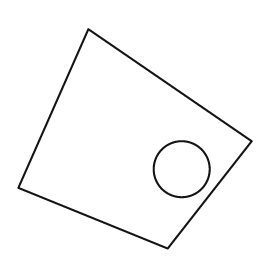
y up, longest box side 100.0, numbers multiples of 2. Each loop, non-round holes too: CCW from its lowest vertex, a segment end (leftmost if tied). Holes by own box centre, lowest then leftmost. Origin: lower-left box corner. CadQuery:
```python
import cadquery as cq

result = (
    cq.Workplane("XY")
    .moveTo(64.0, 0.0)
    .lineTo(100.0, 46.0)
    .lineTo(30.0, 94.0)
    .lineTo(0.0, 26.0)
    .close()
    .moveTo(70.0, 34.0)
    .circle(12.0)
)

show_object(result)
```